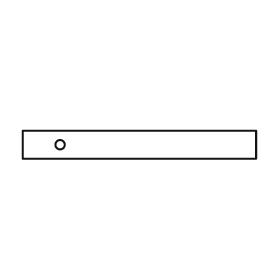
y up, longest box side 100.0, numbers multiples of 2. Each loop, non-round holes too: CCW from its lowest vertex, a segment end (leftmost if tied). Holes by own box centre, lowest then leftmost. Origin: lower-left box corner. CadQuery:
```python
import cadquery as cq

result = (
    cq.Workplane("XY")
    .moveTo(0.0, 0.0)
    .lineTo(100.0, 0.0)
    .lineTo(100.0, 12.0)
    .lineTo(0.0, 12.0)
    .close()
    .moveTo(16.0, 6.0)
    .circle(2.0)
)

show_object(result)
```